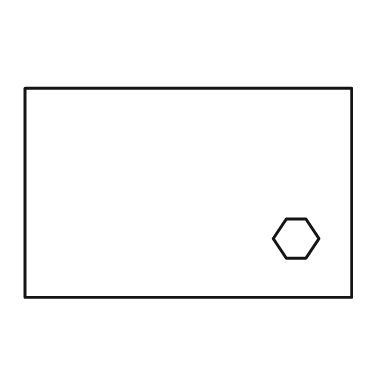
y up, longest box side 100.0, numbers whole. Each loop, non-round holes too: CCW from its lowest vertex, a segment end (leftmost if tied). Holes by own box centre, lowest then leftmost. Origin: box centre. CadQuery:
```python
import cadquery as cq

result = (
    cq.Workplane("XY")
    .moveTo(-50.0, -32.0)
    .lineTo(50.0, -32.0)
    .lineTo(50.0, 32.0)
    .lineTo(-50.0, 32.0)
    .close()
    .moveTo(30.0, -20.0)
    .lineTo(36.0, -20.0)
    .lineTo(40.0, -14.0)
    .lineTo(36.0, -8.0)
    .lineTo(30.0, -8.0)
    .lineTo(26.0, -14.0)
    .close()
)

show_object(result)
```